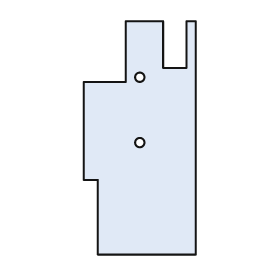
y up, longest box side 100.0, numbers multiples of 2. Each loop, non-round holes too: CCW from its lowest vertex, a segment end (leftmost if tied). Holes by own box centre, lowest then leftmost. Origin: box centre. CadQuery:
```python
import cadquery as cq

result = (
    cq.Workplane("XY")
    .moveTo(-18.0, -50.0)
    .lineTo(24.0, -50.0)
    .lineTo(24.0, 50.0)
    .lineTo(20.0, 50.0)
    .lineTo(20.0, 30.0)
    .lineTo(10.0, 30.0)
    .lineTo(10.0, 50.0)
    .lineTo(-6.0, 50.0)
    .lineTo(-6.0, 24.0)
    .lineTo(-24.0, 24.0)
    .lineTo(-24.0, -18.0)
    .lineTo(-18.0, -18.0)
    .close()
    .moveTo(0.0, -2.0)
    .circle(2.0)
    .moveTo(0.0, 26.0)
    .circle(2.0)
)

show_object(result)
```